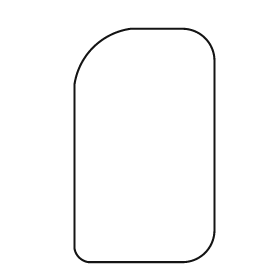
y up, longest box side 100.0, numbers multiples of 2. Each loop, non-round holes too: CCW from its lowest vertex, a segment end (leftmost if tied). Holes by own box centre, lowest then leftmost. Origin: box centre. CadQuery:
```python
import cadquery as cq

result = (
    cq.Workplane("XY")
    .moveTo(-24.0, -50.0)
    .lineTo(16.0, -50.0)
    .threePointArc((26.0, -46.0), (30.0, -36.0))
    .lineTo(30.0, 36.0)
    .threePointArc((26.0, 46.0), (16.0, 50.0))
    .lineTo(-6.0, 50.0)
    .threePointArc((-22.0, 42.0), (-30.0, 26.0))
    .lineTo(-30.0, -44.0)
    .threePointArc((-28.0, -48.0), (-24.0, -50.0))
    .close()
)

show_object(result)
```